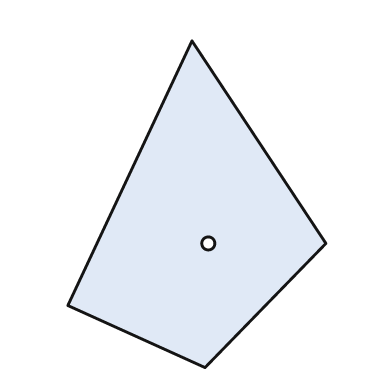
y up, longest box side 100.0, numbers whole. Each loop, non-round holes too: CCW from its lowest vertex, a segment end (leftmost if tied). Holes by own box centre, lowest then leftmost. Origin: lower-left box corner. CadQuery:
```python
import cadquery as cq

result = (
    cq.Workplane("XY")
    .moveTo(42.0, 0.0)
    .lineTo(79.0, 38.0)
    .lineTo(38.0, 100.0)
    .lineTo(0.0, 19.0)
    .close()
    .moveTo(43.0, 38.0)
    .circle(2.0)
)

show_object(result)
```